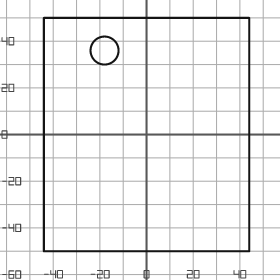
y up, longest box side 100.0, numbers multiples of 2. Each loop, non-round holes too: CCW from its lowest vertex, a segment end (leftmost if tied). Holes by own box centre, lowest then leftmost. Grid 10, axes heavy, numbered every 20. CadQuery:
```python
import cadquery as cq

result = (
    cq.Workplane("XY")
    .moveTo(-44.0, -50.0)
    .lineTo(44.0, -50.0)
    .lineTo(44.0, 50.0)
    .lineTo(-44.0, 50.0)
    .close()
    .moveTo(-18.0, 36.0)
    .circle(6.0)
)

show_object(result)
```